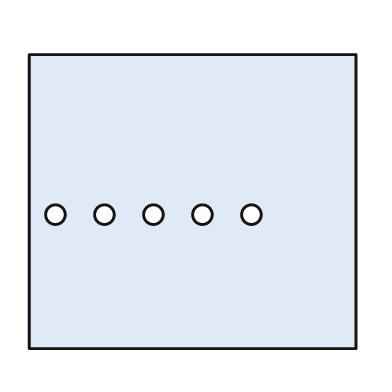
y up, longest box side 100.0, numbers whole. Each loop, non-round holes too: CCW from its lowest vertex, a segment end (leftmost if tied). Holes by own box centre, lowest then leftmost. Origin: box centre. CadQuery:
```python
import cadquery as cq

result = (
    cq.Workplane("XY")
    .moveTo(-50.0, -45.0)
    .lineTo(50.0, -45.0)
    .lineTo(50.0, 45.0)
    .lineTo(-50.0, 45.0)
    .close()
    .moveTo(-42.0, -4.0)
    .circle(3.0)
    .moveTo(-27.0, -4.0)
    .circle(3.0)
    .moveTo(-12.0, -4.0)
    .circle(3.0)
    .moveTo(3.0, -4.0)
    .circle(3.0)
    .moveTo(18.0, -4.0)
    .circle(3.0)
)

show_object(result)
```